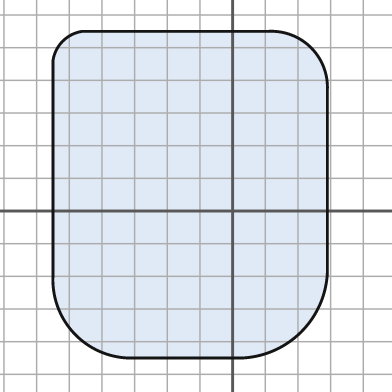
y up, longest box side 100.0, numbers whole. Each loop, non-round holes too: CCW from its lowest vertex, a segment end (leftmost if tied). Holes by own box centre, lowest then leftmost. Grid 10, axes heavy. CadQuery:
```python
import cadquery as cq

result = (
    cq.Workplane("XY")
    .moveTo(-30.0, -45.0)
    .lineTo(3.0, -45.0)
    .threePointArc((21.0, -37.0), (29.0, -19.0))
    .lineTo(29.0, 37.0)
    .threePointArc((24.0, 50.0), (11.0, 55.0))
    .lineTo(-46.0, 55.0)
    .threePointArc((-52.0, 52.0), (-55.0, 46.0))
    .lineTo(-55.0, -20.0)
    .threePointArc((-48.0, -38.0), (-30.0, -45.0))
    .close()
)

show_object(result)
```